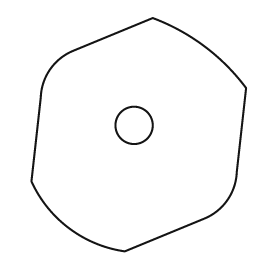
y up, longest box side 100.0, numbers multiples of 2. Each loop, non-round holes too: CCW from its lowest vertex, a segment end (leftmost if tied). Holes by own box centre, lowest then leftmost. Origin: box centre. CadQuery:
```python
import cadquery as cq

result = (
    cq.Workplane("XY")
    .moveTo(-6.0, -50.0)
    .lineTo(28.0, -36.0)
    .threePointArc((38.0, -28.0), (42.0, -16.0))
    .lineTo(46.0, 20.0)
    .threePointArc((28.0, 38.0), (6.0, 50.0))
    .lineTo(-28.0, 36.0)
    .threePointArc((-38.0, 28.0), (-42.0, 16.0))
    .lineTo(-46.0, -20.0)
    .threePointArc((-30.0, -40.0), (-6.0, -50.0))
    .close()
    .moveTo(-2.0, 4.0)
    .circle(8.0)
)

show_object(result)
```